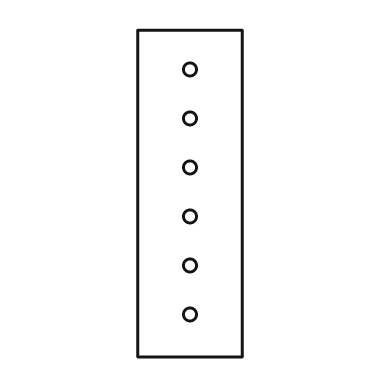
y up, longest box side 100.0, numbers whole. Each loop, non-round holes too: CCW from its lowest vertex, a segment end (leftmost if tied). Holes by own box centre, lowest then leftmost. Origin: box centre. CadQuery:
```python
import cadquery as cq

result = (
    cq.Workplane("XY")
    .moveTo(-16.0, -50.0)
    .lineTo(16.0, -50.0)
    .lineTo(16.0, 50.0)
    .lineTo(-16.0, 50.0)
    .close()
    .moveTo(0.0, -37.0)
    .circle(2.0)
    .moveTo(0.0, -22.0)
    .circle(2.0)
    .moveTo(0.0, -7.0)
    .circle(2.0)
    .moveTo(0.0, 8.0)
    .circle(2.0)
    .moveTo(0.0, 23.0)
    .circle(2.0)
    .moveTo(0.0, 38.0)
    .circle(2.0)
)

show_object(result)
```